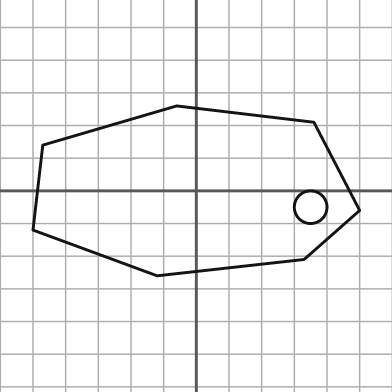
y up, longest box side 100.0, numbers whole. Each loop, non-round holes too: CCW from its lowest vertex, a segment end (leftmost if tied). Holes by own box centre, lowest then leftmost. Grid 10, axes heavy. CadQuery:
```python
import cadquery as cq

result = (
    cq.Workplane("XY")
    .moveTo(-12.0, -26.0)
    .lineTo(33.0, -21.0)
    .lineTo(50.0, -6.0)
    .lineTo(36.0, 21.0)
    .lineTo(-6.0, 26.0)
    .lineTo(-47.0, 14.0)
    .lineTo(-50.0, -12.0)
    .close()
    .moveTo(35.0, -5.0)
    .circle(5.0)
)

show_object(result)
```